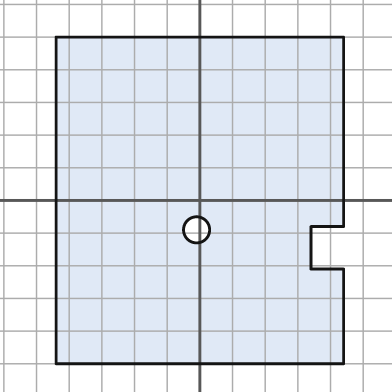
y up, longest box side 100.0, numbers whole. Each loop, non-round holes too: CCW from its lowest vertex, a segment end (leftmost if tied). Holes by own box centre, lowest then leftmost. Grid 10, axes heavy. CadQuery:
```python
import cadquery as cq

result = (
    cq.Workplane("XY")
    .moveTo(-44.0, -50.0)
    .lineTo(44.0, -50.0)
    .lineTo(44.0, -21.0)
    .lineTo(34.0, -21.0)
    .lineTo(34.0, -8.0)
    .lineTo(44.0, -8.0)
    .lineTo(44.0, 50.0)
    .lineTo(-44.0, 50.0)
    .close()
    .moveTo(-1.0, -9.0)
    .circle(4.0)
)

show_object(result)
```